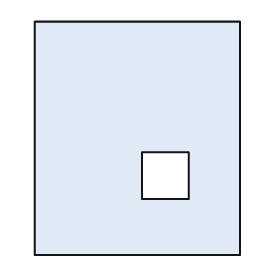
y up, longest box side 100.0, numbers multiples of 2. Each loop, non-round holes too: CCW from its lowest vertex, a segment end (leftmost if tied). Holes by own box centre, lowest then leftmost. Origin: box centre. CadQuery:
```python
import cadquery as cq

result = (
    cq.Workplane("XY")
    .moveTo(-44.0, -50.0)
    .lineTo(44.0, -50.0)
    .lineTo(44.0, 50.0)
    .lineTo(-44.0, 50.0)
    .close()
    .moveTo(2.0, -26.0)
    .lineTo(22.0, -26.0)
    .lineTo(22.0, -6.0)
    .lineTo(2.0, -6.0)
    .close()
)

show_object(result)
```